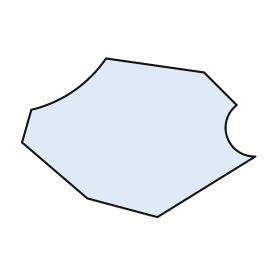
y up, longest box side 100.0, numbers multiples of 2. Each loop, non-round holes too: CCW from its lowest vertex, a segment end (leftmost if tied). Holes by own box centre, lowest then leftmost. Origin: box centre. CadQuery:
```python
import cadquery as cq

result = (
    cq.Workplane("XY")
    .moveTo(8.0, -34.0)
    .lineTo(50.0, -8.0)
    .threePointArc((38.0, 0.0), (42.0, 14.0))
    .lineTo(28.0, 28.0)
    .lineTo(-14.0, 34.0)
    .threePointArc((-28.0, 20.0), (-46.0, 12.0))
    .lineTo(-50.0, -2.0)
    .lineTo(-22.0, -26.0)
    .close()
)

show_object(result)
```